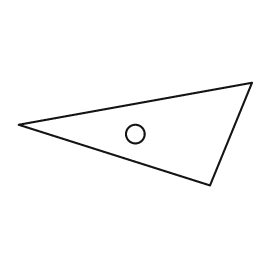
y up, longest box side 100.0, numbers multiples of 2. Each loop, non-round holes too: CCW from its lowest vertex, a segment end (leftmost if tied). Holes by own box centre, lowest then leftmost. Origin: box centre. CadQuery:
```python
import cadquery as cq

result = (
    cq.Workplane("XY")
    .moveTo(32.0, -22.0)
    .lineTo(50.0, 22.0)
    .lineTo(-50.0, 4.0)
    .close()
    .moveTo(0.0, 0.0)
    .circle(4.0)
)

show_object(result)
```